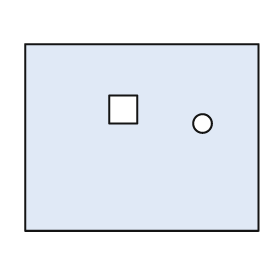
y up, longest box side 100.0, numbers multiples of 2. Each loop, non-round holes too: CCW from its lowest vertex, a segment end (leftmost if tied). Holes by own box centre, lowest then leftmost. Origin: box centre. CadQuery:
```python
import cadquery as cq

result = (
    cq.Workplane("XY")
    .moveTo(-50.0, -40.0)
    .lineTo(50.0, -40.0)
    .lineTo(50.0, 40.0)
    .lineTo(-50.0, 40.0)
    .close()
    .moveTo(26.0, 6.0)
    .circle(4.0)
    .moveTo(-14.0, 6.0)
    .lineTo(-2.0, 6.0)
    .lineTo(-2.0, 18.0)
    .lineTo(-14.0, 18.0)
    .close()
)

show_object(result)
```